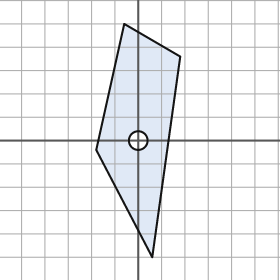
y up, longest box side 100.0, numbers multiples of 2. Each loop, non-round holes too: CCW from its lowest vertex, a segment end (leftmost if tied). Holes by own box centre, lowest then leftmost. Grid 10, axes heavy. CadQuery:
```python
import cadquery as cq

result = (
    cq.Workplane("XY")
    .moveTo(6.0, -50.0)
    .lineTo(18.0, 36.0)
    .lineTo(-6.0, 50.0)
    .lineTo(-18.0, -4.0)
    .close()
    .moveTo(0.0, 0.0)
    .circle(4.0)
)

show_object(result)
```